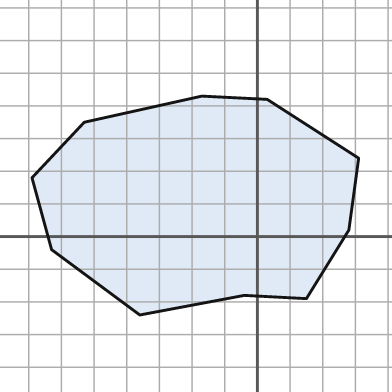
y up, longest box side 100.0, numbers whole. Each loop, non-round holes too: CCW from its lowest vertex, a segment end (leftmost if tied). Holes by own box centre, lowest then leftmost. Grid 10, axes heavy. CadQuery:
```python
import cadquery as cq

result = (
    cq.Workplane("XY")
    .moveTo(-36.0, -24.0)
    .lineTo(-4.0, -18.0)
    .lineTo(15.0, -19.0)
    .lineTo(28.0, 2.0)
    .lineTo(31.0, 24.0)
    .lineTo(3.0, 42.0)
    .lineTo(-17.0, 43.0)
    .lineTo(-53.0, 35.0)
    .lineTo(-69.0, 18.0)
    .lineTo(-63.0, -4.0)
    .close()
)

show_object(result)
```